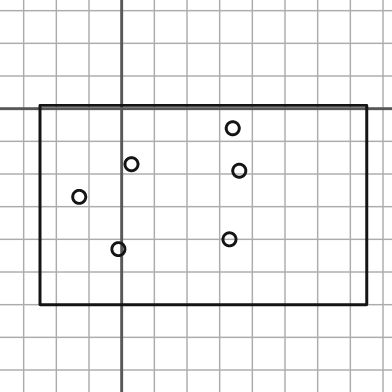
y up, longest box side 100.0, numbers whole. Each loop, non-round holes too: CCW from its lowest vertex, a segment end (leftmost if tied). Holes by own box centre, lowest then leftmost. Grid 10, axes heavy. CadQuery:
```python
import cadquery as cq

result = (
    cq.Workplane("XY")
    .moveTo(-25.0, -60.0)
    .lineTo(75.0, -60.0)
    .lineTo(75.0, 1.0)
    .lineTo(-25.0, 1.0)
    .close()
    .moveTo(-1.0, -43.0)
    .circle(2.0)
    .moveTo(33.0, -40.0)
    .circle(2.0)
    .moveTo(-13.0, -27.0)
    .circle(2.0)
    .moveTo(36.0, -19.0)
    .circle(2.0)
    .moveTo(3.0, -17.0)
    .circle(2.0)
    .moveTo(34.0, -6.0)
    .circle(2.0)
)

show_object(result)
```